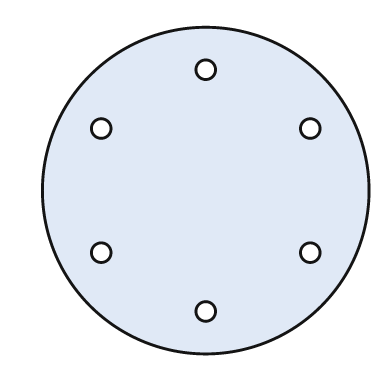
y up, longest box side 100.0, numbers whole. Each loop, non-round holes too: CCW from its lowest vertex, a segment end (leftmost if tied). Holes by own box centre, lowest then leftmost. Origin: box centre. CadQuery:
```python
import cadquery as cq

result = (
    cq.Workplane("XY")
    .moveTo(0.0, 0.0)
    .circle(50.0)
    .moveTo(0.0, -37.0)
    .circle(3.0)
    .moveTo(-32.0, -19.0)
    .circle(3.0)
    .moveTo(32.0, -19.0)
    .circle(3.0)
    .moveTo(-32.0, 19.0)
    .circle(3.0)
    .moveTo(32.0, 19.0)
    .circle(3.0)
    .moveTo(0.0, 37.0)
    .circle(3.0)
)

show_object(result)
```